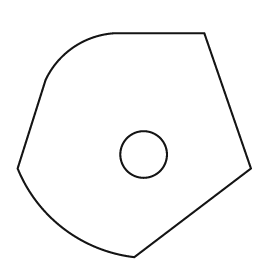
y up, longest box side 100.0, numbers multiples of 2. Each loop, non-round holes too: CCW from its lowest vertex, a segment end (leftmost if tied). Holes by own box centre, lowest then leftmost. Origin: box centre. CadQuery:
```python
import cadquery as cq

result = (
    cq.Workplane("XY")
    .moveTo(0.0, -48.0)
    .lineTo(50.0, -10.0)
    .lineTo(30.0, 48.0)
    .lineTo(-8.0, 48.0)
    .threePointArc((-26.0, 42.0), (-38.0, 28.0))
    .lineTo(-50.0, -10.0)
    .threePointArc((-30.0, -36.0), (0.0, -48.0))
    .close()
    .moveTo(4.0, -4.0)
    .circle(10.0)
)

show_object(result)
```